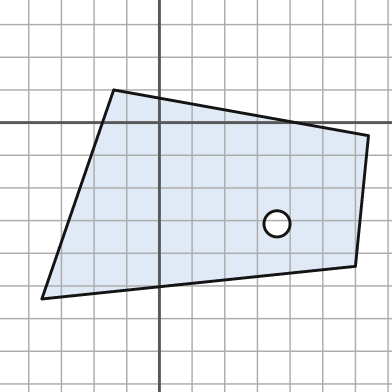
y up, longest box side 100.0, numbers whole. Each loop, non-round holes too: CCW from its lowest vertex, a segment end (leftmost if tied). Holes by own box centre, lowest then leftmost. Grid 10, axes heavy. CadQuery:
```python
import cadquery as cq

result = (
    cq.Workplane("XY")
    .moveTo(-36.0, -54.0)
    .lineTo(60.0, -44.0)
    .lineTo(64.0, -4.0)
    .lineTo(-14.0, 10.0)
    .close()
    .moveTo(36.0, -31.0)
    .circle(4.0)
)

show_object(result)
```